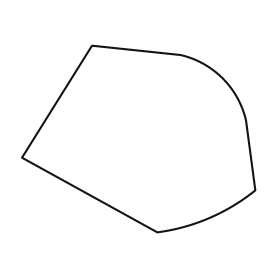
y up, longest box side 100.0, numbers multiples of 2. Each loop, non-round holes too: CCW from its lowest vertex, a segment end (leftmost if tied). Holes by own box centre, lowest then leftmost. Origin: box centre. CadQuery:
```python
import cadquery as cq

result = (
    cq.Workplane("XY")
    .moveTo(8.0, -40.0)
    .threePointArc((30.0, -34.0), (50.0, -22.0))
    .lineTo(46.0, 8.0)
    .threePointArc((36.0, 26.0), (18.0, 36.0))
    .lineTo(-20.0, 40.0)
    .lineTo(-50.0, -8.0)
    .close()
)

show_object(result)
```